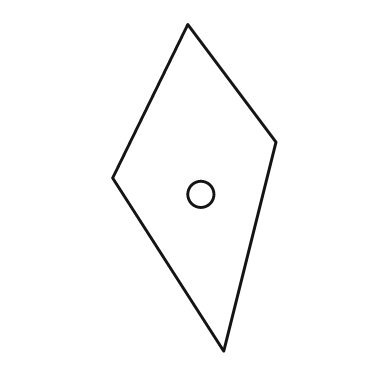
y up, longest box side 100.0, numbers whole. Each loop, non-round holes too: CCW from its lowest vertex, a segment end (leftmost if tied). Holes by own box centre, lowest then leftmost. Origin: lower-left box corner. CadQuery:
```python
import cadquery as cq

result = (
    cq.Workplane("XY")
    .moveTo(34.0, 0.0)
    .lineTo(50.0, 64.0)
    .lineTo(23.0, 100.0)
    .lineTo(0.0, 53.0)
    .close()
    .moveTo(27.0, 48.0)
    .circle(4.0)
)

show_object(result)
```